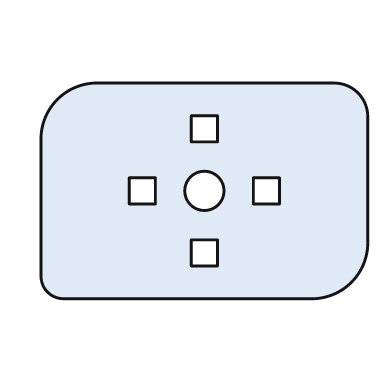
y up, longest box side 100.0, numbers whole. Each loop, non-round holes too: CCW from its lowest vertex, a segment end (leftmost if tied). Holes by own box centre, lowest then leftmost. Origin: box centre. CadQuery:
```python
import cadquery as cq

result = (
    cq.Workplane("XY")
    .moveTo(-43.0, -33.0)
    .lineTo(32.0, -33.0)
    .threePointArc((45.0, -28.0), (50.0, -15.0))
    .lineTo(50.0, 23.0)
    .threePointArc((47.0, 30.0), (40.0, 33.0))
    .lineTo(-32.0, 33.0)
    .threePointArc((-45.0, 28.0), (-50.0, 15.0))
    .lineTo(-50.0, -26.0)
    .threePointArc((-48.0, -31.0), (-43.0, -33.0))
    .close()
    .moveTo(-4.0, -23.0)
    .lineTo(4.0, -23.0)
    .lineTo(4.0, -15.0)
    .lineTo(-4.0, -15.0)
    .close()
    .moveTo(-23.0, -4.0)
    .lineTo(-15.0, -4.0)
    .lineTo(-15.0, 4.0)
    .lineTo(-23.0, 4.0)
    .close()
    .moveTo(0.0, 0.0)
    .circle(6.0)
    .moveTo(15.0, -4.0)
    .lineTo(23.0, -4.0)
    .lineTo(23.0, 4.0)
    .lineTo(15.0, 4.0)
    .close()
    .moveTo(-4.0, 15.0)
    .lineTo(4.0, 15.0)
    .lineTo(4.0, 23.0)
    .lineTo(-4.0, 23.0)
    .close()
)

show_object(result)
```